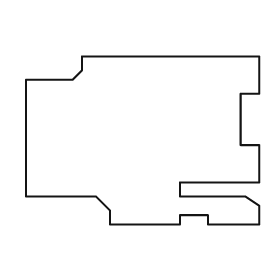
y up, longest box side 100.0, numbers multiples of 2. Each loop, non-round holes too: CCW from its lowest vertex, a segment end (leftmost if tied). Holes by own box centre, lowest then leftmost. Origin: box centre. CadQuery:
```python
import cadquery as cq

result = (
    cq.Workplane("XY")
    .moveTo(-14.0, -36.0)
    .lineTo(16.0, -36.0)
    .lineTo(16.0, -32.0)
    .lineTo(28.0, -32.0)
    .lineTo(28.0, -36.0)
    .lineTo(50.0, -36.0)
    .lineTo(50.0, -28.0)
    .lineTo(44.0, -24.0)
    .lineTo(16.0, -24.0)
    .lineTo(16.0, -18.0)
    .lineTo(50.0, -18.0)
    .lineTo(50.0, -2.0)
    .lineTo(42.0, -2.0)
    .lineTo(42.0, 20.0)
    .lineTo(50.0, 20.0)
    .lineTo(50.0, 36.0)
    .lineTo(-26.0, 36.0)
    .lineTo(-26.0, 30.0)
    .lineTo(-30.0, 26.0)
    .lineTo(-50.0, 26.0)
    .lineTo(-50.0, -24.0)
    .lineTo(-20.0, -24.0)
    .lineTo(-14.0, -30.0)
    .close()
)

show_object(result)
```